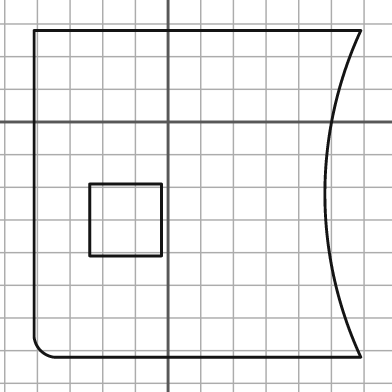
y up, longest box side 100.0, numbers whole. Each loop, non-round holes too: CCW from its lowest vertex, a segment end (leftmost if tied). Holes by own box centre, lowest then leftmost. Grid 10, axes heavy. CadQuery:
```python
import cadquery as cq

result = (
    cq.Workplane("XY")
    .moveTo(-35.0, -72.0)
    .lineTo(59.0, -72.0)
    .threePointArc((48.0, -22.0), (59.0, 28.0))
    .lineTo(-41.0, 28.0)
    .lineTo(-41.0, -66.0)
    .threePointArc((-39.0, -70.0), (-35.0, -72.0))
    .close()
    .moveTo(-24.0, -41.0)
    .lineTo(-2.0, -41.0)
    .lineTo(-2.0, -19.0)
    .lineTo(-24.0, -19.0)
    .close()
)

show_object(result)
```